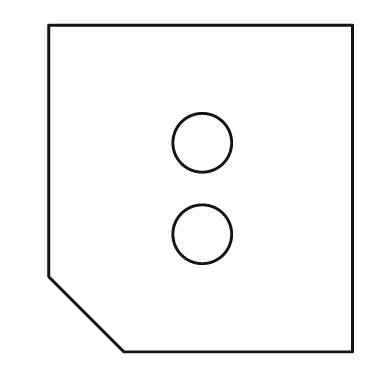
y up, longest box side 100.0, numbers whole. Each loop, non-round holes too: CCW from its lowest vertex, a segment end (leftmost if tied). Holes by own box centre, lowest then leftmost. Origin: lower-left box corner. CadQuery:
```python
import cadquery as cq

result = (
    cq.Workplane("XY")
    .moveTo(23.0, 0.0)
    .lineTo(93.0, 0.0)
    .lineTo(93.0, 100.0)
    .lineTo(0.0, 100.0)
    .lineTo(0.0, 23.0)
    .close()
    .moveTo(47.0, 36.0)
    .circle(9.0)
    .moveTo(47.0, 64.0)
    .circle(9.0)
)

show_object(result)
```